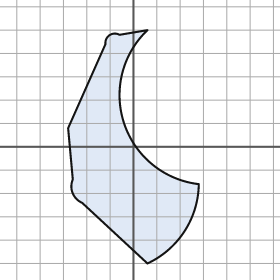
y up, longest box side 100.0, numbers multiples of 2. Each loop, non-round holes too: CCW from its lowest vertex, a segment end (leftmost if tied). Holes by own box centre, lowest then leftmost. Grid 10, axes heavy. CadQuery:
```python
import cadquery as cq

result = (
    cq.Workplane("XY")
    .moveTo(6.0, -50.0)
    .threePointArc((22.0, -36.0), (28.0, -16.0))
    .threePointArc((-4.0, 10.0), (6.0, 50.0))
    .lineTo(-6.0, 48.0)
    .threePointArc((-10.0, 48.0), (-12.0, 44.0))
    .lineTo(-28.0, 8.0)
    .lineTo(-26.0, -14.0)
    .threePointArc((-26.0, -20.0), (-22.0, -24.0))
    .close()
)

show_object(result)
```